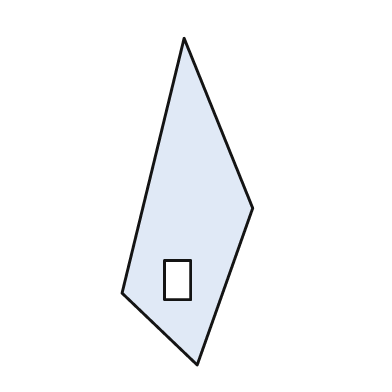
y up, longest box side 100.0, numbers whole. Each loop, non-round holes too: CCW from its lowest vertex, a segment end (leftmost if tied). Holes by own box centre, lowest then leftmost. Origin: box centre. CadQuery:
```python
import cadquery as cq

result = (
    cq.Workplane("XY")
    .moveTo(3.0, -50.0)
    .lineTo(20.0, -2.0)
    .lineTo(-1.0, 50.0)
    .lineTo(-20.0, -28.0)
    .close()
    .moveTo(-7.0, -30.0)
    .lineTo(1.0, -30.0)
    .lineTo(1.0, -18.0)
    .lineTo(-7.0, -18.0)
    .close()
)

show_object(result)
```